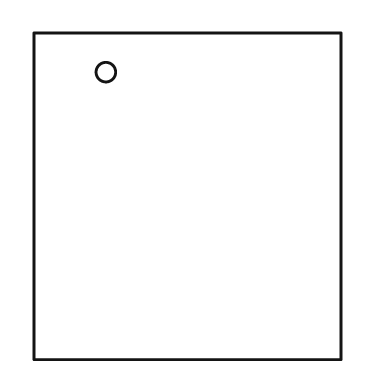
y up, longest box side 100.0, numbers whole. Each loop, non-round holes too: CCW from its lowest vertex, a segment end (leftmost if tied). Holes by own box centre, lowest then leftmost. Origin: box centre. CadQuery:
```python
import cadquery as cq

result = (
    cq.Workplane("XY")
    .moveTo(-47.0, -50.0)
    .lineTo(47.0, -50.0)
    .lineTo(47.0, 50.0)
    .lineTo(-47.0, 50.0)
    .close()
    .moveTo(-25.0, 38.0)
    .circle(3.0)
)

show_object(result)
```